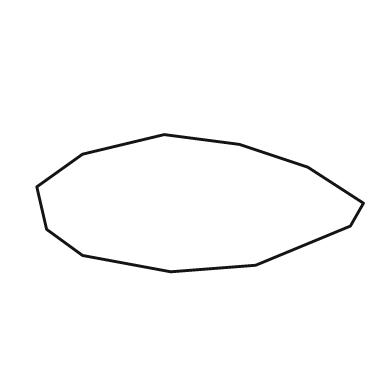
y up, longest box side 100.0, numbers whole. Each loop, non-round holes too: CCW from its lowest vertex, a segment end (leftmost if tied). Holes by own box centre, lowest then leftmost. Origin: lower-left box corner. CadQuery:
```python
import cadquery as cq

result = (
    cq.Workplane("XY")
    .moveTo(41.0, 0.0)
    .lineTo(67.0, 2.0)
    .lineTo(96.0, 14.0)
    .lineTo(100.0, 21.0)
    .lineTo(83.0, 32.0)
    .lineTo(62.0, 39.0)
    .lineTo(39.0, 42.0)
    .lineTo(14.0, 36.0)
    .lineTo(0.0, 26.0)
    .lineTo(3.0, 13.0)
    .lineTo(14.0, 5.0)
    .close()
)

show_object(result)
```